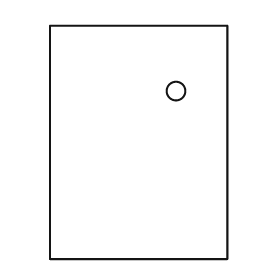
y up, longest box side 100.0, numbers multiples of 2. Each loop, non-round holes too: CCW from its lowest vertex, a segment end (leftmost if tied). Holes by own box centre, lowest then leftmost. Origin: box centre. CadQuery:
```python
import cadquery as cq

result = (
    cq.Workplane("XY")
    .moveTo(-38.0, -50.0)
    .lineTo(38.0, -50.0)
    .lineTo(38.0, 50.0)
    .lineTo(-38.0, 50.0)
    .close()
    .moveTo(16.0, 22.0)
    .circle(4.0)
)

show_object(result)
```